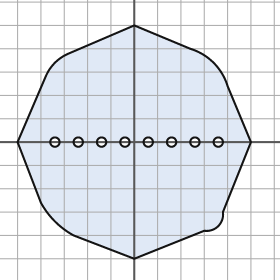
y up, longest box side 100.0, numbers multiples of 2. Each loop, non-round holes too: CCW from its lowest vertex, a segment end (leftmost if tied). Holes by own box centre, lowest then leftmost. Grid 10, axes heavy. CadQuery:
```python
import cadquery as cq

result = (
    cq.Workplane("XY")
    .moveTo(0.0, -50.0)
    .lineTo(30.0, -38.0)
    .threePointArc((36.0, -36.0), (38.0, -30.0))
    .lineTo(50.0, 0.0)
    .lineTo(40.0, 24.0)
    .threePointArc((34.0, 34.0), (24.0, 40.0))
    .lineTo(0.0, 50.0)
    .lineTo(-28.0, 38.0)
    .threePointArc((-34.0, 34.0), (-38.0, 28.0))
    .lineTo(-50.0, 0.0)
    .lineTo(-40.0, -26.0)
    .threePointArc((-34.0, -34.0), (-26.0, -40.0))
    .close()
    .moveTo(-34.0, 0.0)
    .circle(2.0)
    .moveTo(-24.0, 0.0)
    .circle(2.0)
    .moveTo(-14.0, 0.0)
    .circle(2.0)
    .moveTo(-4.0, 0.0)
    .circle(2.0)
    .moveTo(6.0, 0.0)
    .circle(2.0)
    .moveTo(16.0, 0.0)
    .circle(2.0)
    .moveTo(26.0, 0.0)
    .circle(2.0)
    .moveTo(36.0, 0.0)
    .circle(2.0)
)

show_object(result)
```